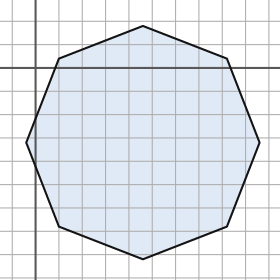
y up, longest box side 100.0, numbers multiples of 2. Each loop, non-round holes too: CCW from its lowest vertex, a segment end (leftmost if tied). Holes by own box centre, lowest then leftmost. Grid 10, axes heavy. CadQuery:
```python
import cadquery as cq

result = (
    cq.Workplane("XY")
    .moveTo(46.0, -82.0)
    .lineTo(82.0, -68.0)
    .lineTo(96.0, -32.0)
    .lineTo(82.0, 4.0)
    .lineTo(46.0, 18.0)
    .lineTo(10.0, 4.0)
    .lineTo(-4.0, -32.0)
    .lineTo(10.0, -68.0)
    .close()
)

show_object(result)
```